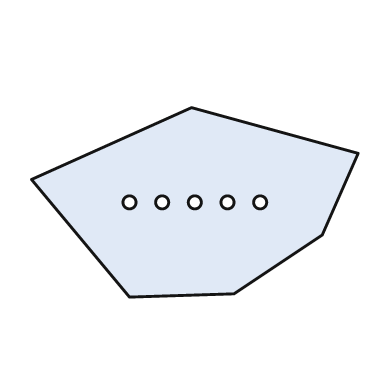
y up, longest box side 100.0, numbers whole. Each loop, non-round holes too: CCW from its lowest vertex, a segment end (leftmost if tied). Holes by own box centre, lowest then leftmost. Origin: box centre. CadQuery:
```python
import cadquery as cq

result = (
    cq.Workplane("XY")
    .moveTo(-20.0, -29.0)
    .lineTo(12.0, -28.0)
    .lineTo(39.0, -10.0)
    .lineTo(50.0, 15.0)
    .lineTo(-1.0, 29.0)
    .lineTo(-50.0, 7.0)
    .close()
    .moveTo(-20.0, 0.0)
    .circle(2.0)
    .moveTo(-10.0, 0.0)
    .circle(2.0)
    .moveTo(0.0, 0.0)
    .circle(2.0)
    .moveTo(10.0, 0.0)
    .circle(2.0)
    .moveTo(20.0, 0.0)
    .circle(2.0)
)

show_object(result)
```